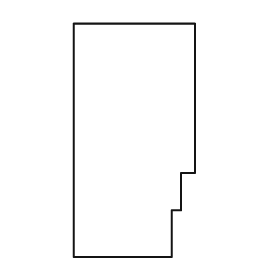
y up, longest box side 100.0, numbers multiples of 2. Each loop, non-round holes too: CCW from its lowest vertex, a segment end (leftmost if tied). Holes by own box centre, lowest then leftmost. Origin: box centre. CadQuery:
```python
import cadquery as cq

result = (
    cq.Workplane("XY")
    .moveTo(-26.0, -50.0)
    .lineTo(16.0, -50.0)
    .lineTo(16.0, -30.0)
    .lineTo(20.0, -30.0)
    .lineTo(20.0, -14.0)
    .lineTo(26.0, -14.0)
    .lineTo(26.0, 50.0)
    .lineTo(-26.0, 50.0)
    .close()
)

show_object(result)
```